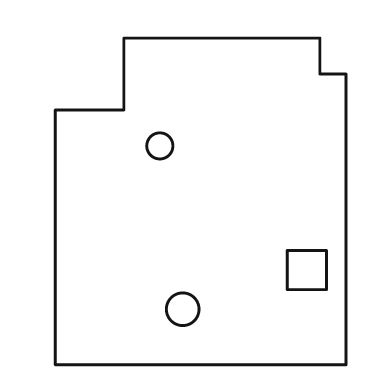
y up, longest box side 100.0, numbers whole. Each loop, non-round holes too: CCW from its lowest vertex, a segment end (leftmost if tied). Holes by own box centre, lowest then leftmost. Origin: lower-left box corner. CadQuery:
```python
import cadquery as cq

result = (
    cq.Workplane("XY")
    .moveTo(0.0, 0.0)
    .lineTo(89.0, 0.0)
    .lineTo(89.0, 89.0)
    .lineTo(81.0, 89.0)
    .lineTo(81.0, 100.0)
    .lineTo(21.0, 100.0)
    .lineTo(21.0, 78.0)
    .lineTo(0.0, 78.0)
    .close()
    .moveTo(39.0, 17.0)
    .circle(5.0)
    .moveTo(71.0, 23.0)
    .lineTo(83.0, 23.0)
    .lineTo(83.0, 35.0)
    .lineTo(71.0, 35.0)
    .close()
    .moveTo(32.0, 67.0)
    .circle(4.0)
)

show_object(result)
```